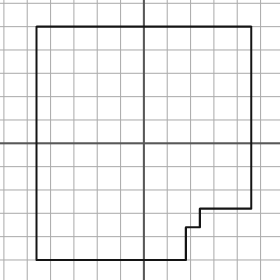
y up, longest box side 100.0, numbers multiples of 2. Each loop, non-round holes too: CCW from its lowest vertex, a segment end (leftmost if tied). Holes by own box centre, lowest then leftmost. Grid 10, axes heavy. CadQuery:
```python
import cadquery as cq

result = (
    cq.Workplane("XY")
    .moveTo(-46.0, -50.0)
    .lineTo(18.0, -50.0)
    .lineTo(18.0, -36.0)
    .lineTo(24.0, -36.0)
    .lineTo(24.0, -28.0)
    .lineTo(46.0, -28.0)
    .lineTo(46.0, 50.0)
    .lineTo(-46.0, 50.0)
    .close()
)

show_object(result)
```